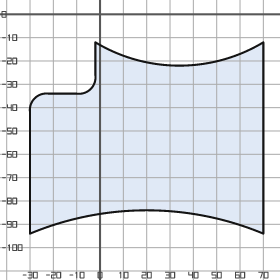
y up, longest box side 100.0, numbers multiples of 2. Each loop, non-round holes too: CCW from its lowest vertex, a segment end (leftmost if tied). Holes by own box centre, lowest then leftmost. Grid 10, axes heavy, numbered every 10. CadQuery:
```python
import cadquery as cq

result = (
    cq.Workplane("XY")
    .moveTo(-30.0, -94.0)
    .threePointArc((20.0, -84.0), (70.0, -94.0))
    .lineTo(70.0, -12.0)
    .threePointArc((34.0, -22.0), (-2.0, -12.0))
    .lineTo(-2.0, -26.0)
    .threePointArc((-4.0, -32.0), (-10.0, -34.0))
    .lineTo(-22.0, -34.0)
    .threePointArc((-28.0, -36.0), (-30.0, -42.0))
    .close()
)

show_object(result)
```